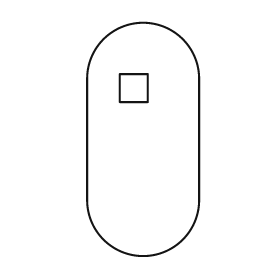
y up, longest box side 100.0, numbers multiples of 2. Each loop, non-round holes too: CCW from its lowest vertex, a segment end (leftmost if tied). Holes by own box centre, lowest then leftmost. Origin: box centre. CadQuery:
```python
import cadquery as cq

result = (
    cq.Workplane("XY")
    .moveTo(-24.0, -26.0)
    .threePointArc((0.0, -50.0), (24.0, -26.0))
    .lineTo(24.0, 26.0)
    .threePointArc((0.0, 50.0), (-24.0, 26.0))
    .close()
    .moveTo(-10.0, 16.0)
    .lineTo(2.0, 16.0)
    .lineTo(2.0, 28.0)
    .lineTo(-10.0, 28.0)
    .close()
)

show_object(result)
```